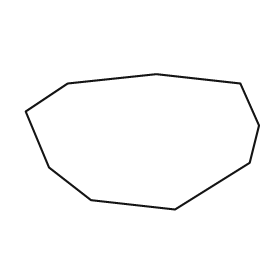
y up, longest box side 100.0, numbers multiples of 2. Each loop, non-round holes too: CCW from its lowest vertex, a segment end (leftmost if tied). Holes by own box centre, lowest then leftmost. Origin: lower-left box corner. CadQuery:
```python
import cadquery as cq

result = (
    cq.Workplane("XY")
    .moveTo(64.0, 0.0)
    .lineTo(96.0, 20.0)
    .lineTo(100.0, 36.0)
    .lineTo(92.0, 54.0)
    .lineTo(56.0, 58.0)
    .lineTo(18.0, 54.0)
    .lineTo(0.0, 42.0)
    .lineTo(10.0, 18.0)
    .lineTo(28.0, 4.0)
    .close()
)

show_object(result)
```